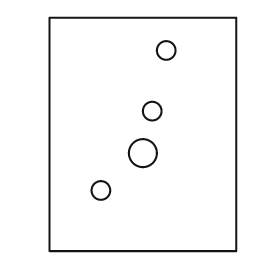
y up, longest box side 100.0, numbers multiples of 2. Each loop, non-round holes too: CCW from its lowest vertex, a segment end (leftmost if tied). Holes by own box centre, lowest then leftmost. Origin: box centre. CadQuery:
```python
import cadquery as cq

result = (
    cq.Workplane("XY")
    .moveTo(-40.0, -50.0)
    .lineTo(40.0, -50.0)
    .lineTo(40.0, 50.0)
    .lineTo(-40.0, 50.0)
    .close()
    .moveTo(-18.0, -24.0)
    .circle(4.0)
    .moveTo(0.0, -8.0)
    .circle(6.0)
    .moveTo(4.0, 10.0)
    .circle(4.0)
    .moveTo(10.0, 36.0)
    .circle(4.0)
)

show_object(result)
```